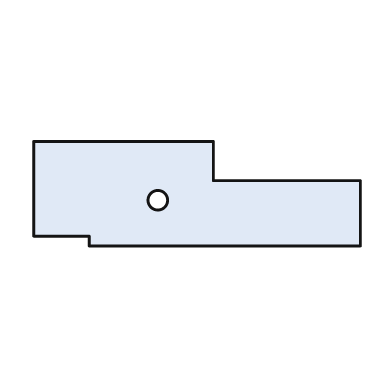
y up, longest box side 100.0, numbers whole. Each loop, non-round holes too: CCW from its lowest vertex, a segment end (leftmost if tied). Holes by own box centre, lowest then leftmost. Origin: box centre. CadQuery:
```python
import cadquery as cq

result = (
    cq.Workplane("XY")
    .moveTo(-33.0, -16.0)
    .lineTo(50.0, -16.0)
    .lineTo(50.0, 4.0)
    .lineTo(5.0, 4.0)
    .lineTo(5.0, 16.0)
    .lineTo(-50.0, 16.0)
    .lineTo(-50.0, -13.0)
    .lineTo(-33.0, -13.0)
    .close()
    .moveTo(-12.0, -2.0)
    .circle(3.0)
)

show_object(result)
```